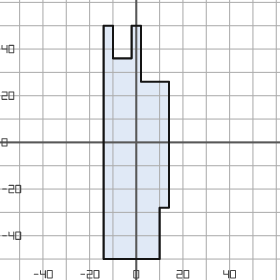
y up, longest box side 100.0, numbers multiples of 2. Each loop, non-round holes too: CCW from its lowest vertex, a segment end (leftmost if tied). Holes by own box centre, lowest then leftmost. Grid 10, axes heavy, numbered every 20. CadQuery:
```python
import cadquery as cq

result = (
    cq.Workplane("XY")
    .moveTo(-14.0, -50.0)
    .lineTo(10.0, -50.0)
    .lineTo(10.0, -28.0)
    .lineTo(14.0, -28.0)
    .lineTo(14.0, 26.0)
    .lineTo(2.0, 26.0)
    .lineTo(2.0, 50.0)
    .lineTo(-2.0, 50.0)
    .lineTo(-2.0, 36.0)
    .lineTo(-10.0, 36.0)
    .lineTo(-10.0, 50.0)
    .lineTo(-14.0, 50.0)
    .close()
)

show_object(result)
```